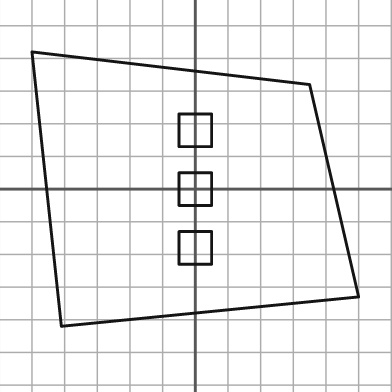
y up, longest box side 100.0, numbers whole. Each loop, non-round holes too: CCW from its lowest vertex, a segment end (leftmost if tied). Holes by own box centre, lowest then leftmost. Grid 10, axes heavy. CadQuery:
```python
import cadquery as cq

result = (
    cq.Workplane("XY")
    .moveTo(-41.0, -42.0)
    .lineTo(50.0, -33.0)
    .lineTo(35.0, 32.0)
    .lineTo(-50.0, 42.0)
    .close()
    .moveTo(-5.0, -23.0)
    .lineTo(5.0, -23.0)
    .lineTo(5.0, -13.0)
    .lineTo(-5.0, -13.0)
    .close()
    .moveTo(-5.0, -5.0)
    .lineTo(5.0, -5.0)
    .lineTo(5.0, 5.0)
    .lineTo(-5.0, 5.0)
    .close()
    .moveTo(-5.0, 13.0)
    .lineTo(5.0, 13.0)
    .lineTo(5.0, 23.0)
    .lineTo(-5.0, 23.0)
    .close()
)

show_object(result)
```